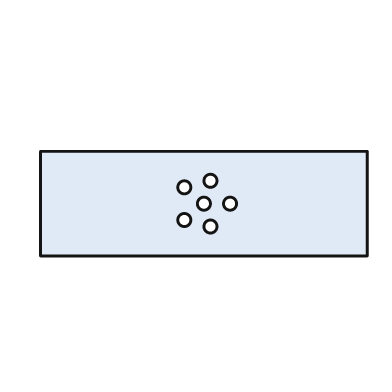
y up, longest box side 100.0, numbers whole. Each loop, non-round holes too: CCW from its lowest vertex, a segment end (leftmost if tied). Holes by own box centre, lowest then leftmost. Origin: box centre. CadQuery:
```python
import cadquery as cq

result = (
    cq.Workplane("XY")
    .moveTo(-50.0, -16.0)
    .lineTo(50.0, -16.0)
    .lineTo(50.0, 16.0)
    .lineTo(-50.0, 16.0)
    .close()
    .moveTo(2.0, -7.0)
    .circle(2.0)
    .moveTo(-6.0, -5.0)
    .circle(2.0)
    .moveTo(0.0, 0.0)
    .circle(2.0)
    .moveTo(8.0, 0.0)
    .circle(2.0)
    .moveTo(-6.0, 5.0)
    .circle(2.0)
    .moveTo(2.0, 7.0)
    .circle(2.0)
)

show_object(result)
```